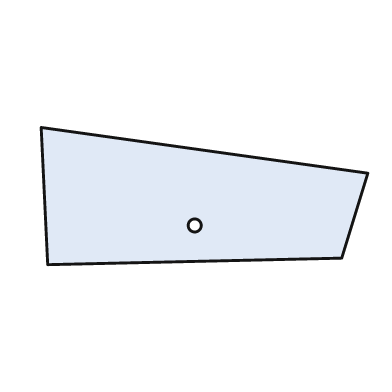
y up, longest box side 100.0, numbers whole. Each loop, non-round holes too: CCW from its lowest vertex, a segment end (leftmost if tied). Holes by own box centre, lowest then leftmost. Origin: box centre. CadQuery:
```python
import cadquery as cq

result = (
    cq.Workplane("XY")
    .moveTo(-48.0, -21.0)
    .lineTo(42.0, -19.0)
    .lineTo(50.0, 7.0)
    .lineTo(-50.0, 21.0)
    .close()
    .moveTo(-3.0, -9.0)
    .circle(2.0)
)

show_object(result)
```